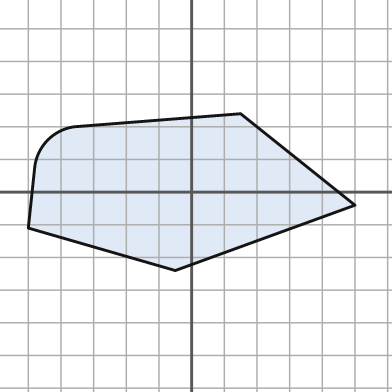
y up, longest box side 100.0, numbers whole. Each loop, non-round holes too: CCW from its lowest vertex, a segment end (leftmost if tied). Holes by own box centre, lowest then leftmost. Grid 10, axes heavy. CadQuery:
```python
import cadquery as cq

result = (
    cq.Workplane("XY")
    .moveTo(-5.0, -24.0)
    .lineTo(50.0, -4.0)
    .lineTo(15.0, 24.0)
    .lineTo(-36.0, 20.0)
    .threePointArc((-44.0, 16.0), (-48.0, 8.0))
    .lineTo(-50.0, -11.0)
    .close()
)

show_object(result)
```